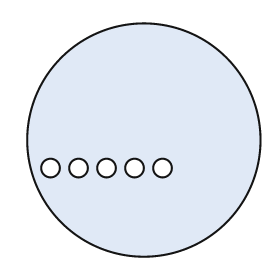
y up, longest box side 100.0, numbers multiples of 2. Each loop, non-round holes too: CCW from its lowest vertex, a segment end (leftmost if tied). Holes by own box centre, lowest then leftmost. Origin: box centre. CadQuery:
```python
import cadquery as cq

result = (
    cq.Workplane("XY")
    .moveTo(0.0, 0.0)
    .circle(50.0)
    .moveTo(-40.0, -12.0)
    .circle(4.0)
    .moveTo(-28.0, -12.0)
    .circle(4.0)
    .moveTo(-16.0, -12.0)
    .circle(4.0)
    .moveTo(-4.0, -12.0)
    .circle(4.0)
    .moveTo(8.0, -12.0)
    .circle(4.0)
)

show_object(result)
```